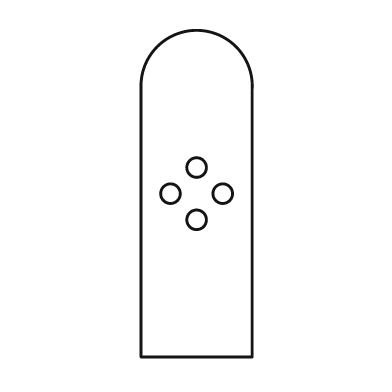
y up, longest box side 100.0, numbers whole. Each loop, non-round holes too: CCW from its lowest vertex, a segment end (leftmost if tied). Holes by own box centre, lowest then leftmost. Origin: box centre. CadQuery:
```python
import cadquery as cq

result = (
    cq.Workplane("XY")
    .moveTo(-17.0, -50.0)
    .lineTo(17.0, -50.0)
    .lineTo(17.0, 32.0)
    .threePointArc((0.0, 50.0), (-17.0, 32.0))
    .close()
    .moveTo(0.0, -8.0)
    .circle(3.0)
    .moveTo(-8.0, 0.0)
    .circle(3.0)
    .moveTo(8.0, 0.0)
    .circle(3.0)
    .moveTo(0.0, 8.0)
    .circle(3.0)
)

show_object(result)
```